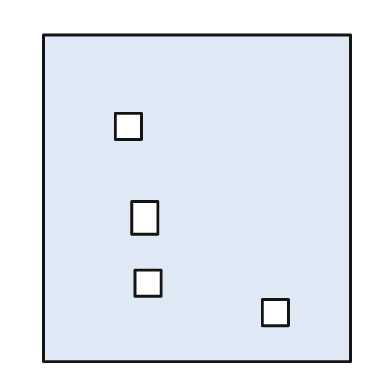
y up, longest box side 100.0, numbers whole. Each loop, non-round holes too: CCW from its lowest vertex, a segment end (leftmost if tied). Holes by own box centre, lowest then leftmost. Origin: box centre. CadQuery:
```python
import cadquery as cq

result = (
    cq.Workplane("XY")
    .moveTo(-47.0, -50.0)
    .lineTo(47.0, -50.0)
    .lineTo(47.0, 50.0)
    .lineTo(-47.0, 50.0)
    .close()
    .moveTo(20.0, -39.0)
    .lineTo(28.0, -39.0)
    .lineTo(28.0, -31.0)
    .lineTo(20.0, -31.0)
    .close()
    .moveTo(-19.0, -30.0)
    .lineTo(-11.0, -30.0)
    .lineTo(-11.0, -22.0)
    .lineTo(-19.0, -22.0)
    .close()
    .moveTo(-20.0, -11.0)
    .lineTo(-12.0, -11.0)
    .lineTo(-12.0, -1.0)
    .lineTo(-20.0, -1.0)
    .close()
    .moveTo(-25.0, 18.0)
    .lineTo(-17.0, 18.0)
    .lineTo(-17.0, 26.0)
    .lineTo(-25.0, 26.0)
    .close()
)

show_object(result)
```